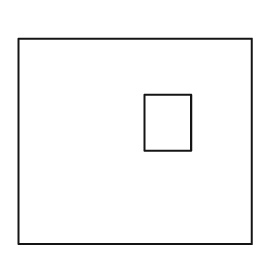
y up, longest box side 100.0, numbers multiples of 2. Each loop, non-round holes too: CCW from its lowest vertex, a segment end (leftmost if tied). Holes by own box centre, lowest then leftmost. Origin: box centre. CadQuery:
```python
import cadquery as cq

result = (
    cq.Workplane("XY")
    .moveTo(-50.0, -44.0)
    .lineTo(50.0, -44.0)
    .lineTo(50.0, 44.0)
    .lineTo(-50.0, 44.0)
    .close()
    .moveTo(4.0, -4.0)
    .lineTo(24.0, -4.0)
    .lineTo(24.0, 20.0)
    .lineTo(4.0, 20.0)
    .close()
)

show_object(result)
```